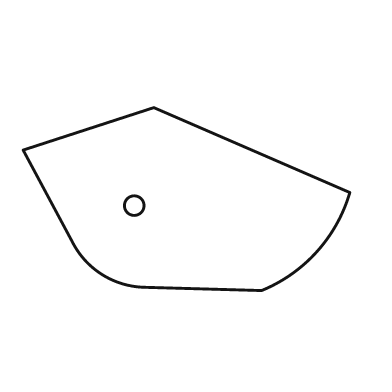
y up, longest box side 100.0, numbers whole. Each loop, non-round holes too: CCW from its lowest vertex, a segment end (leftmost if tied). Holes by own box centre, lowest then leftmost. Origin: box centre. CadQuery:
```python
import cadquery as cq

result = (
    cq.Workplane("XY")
    .moveTo(23.0, -28.0)
    .threePointArc((40.0, -16.0), (50.0, 2.0))
    .lineTo(-10.0, 28.0)
    .lineTo(-50.0, 15.0)
    .lineTo(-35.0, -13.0)
    .threePointArc((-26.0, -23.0), (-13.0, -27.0))
    .close()
    .moveTo(-16.0, -2.0)
    .circle(3.0)
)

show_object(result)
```